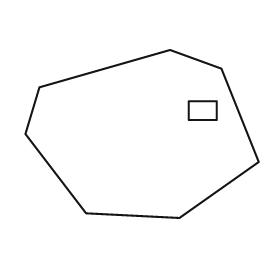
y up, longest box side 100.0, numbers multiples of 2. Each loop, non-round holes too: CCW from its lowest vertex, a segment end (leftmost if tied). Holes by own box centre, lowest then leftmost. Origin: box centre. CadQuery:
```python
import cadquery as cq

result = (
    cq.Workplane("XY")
    .moveTo(16.0, -36.0)
    .lineTo(50.0, -12.0)
    .lineTo(34.0, 28.0)
    .lineTo(12.0, 36.0)
    .lineTo(-44.0, 20.0)
    .lineTo(-50.0, 0.0)
    .lineTo(-24.0, -34.0)
    .close()
    .moveTo(20.0, 6.0)
    .lineTo(32.0, 6.0)
    .lineTo(32.0, 14.0)
    .lineTo(20.0, 14.0)
    .close()
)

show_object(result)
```